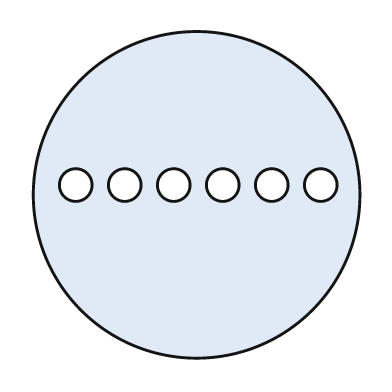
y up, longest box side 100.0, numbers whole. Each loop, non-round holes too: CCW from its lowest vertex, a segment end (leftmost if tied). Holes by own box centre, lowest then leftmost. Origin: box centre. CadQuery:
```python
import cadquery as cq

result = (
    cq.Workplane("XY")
    .moveTo(0.0, 0.0)
    .circle(50.0)
    .moveTo(-37.0, 3.0)
    .circle(5.0)
    .moveTo(-22.0, 3.0)
    .circle(5.0)
    .moveTo(-7.0, 3.0)
    .circle(5.0)
    .moveTo(8.0, 3.0)
    .circle(5.0)
    .moveTo(23.0, 3.0)
    .circle(5.0)
    .moveTo(38.0, 3.0)
    .circle(5.0)
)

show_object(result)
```